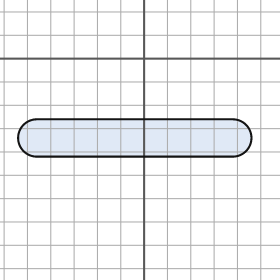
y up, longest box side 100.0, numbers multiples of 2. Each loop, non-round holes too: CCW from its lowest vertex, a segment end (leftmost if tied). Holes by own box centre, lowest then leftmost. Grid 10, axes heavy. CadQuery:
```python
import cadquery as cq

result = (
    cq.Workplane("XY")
    .moveTo(-46.0, -42.0)
    .lineTo(38.0, -42.0)
    .threePointArc((46.0, -34.0), (38.0, -26.0))
    .lineTo(-46.0, -26.0)
    .threePointArc((-54.0, -34.0), (-46.0, -42.0))
    .close()
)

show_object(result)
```